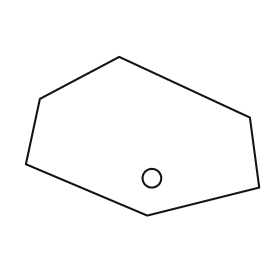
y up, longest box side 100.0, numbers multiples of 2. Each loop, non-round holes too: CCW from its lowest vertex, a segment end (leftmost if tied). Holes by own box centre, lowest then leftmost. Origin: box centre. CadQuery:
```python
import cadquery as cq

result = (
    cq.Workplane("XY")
    .moveTo(2.0, -34.0)
    .lineTo(50.0, -22.0)
    .lineTo(46.0, 8.0)
    .lineTo(-10.0, 34.0)
    .lineTo(-44.0, 16.0)
    .lineTo(-50.0, -12.0)
    .close()
    .moveTo(4.0, -18.0)
    .circle(4.0)
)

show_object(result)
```